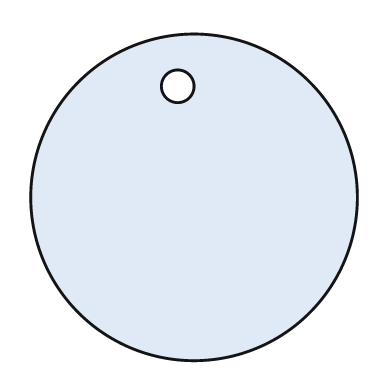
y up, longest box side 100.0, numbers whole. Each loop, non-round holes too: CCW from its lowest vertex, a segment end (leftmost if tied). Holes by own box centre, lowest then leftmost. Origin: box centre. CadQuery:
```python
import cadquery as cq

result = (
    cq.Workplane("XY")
    .moveTo(0.0, 0.0)
    .circle(50.0)
    .moveTo(-5.0, 34.0)
    .circle(5.0)
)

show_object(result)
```